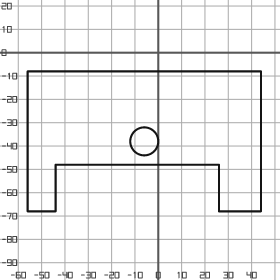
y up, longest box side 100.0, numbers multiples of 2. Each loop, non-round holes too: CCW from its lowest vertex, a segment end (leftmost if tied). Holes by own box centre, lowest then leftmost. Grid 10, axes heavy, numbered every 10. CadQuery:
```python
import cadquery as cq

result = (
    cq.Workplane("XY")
    .moveTo(-56.0, -68.0)
    .lineTo(-44.0, -68.0)
    .lineTo(-44.0, -48.0)
    .lineTo(26.0, -48.0)
    .lineTo(26.0, -68.0)
    .lineTo(44.0, -68.0)
    .lineTo(44.0, -8.0)
    .lineTo(-56.0, -8.0)
    .close()
    .moveTo(-6.0, -38.0)
    .circle(6.0)
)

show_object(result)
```